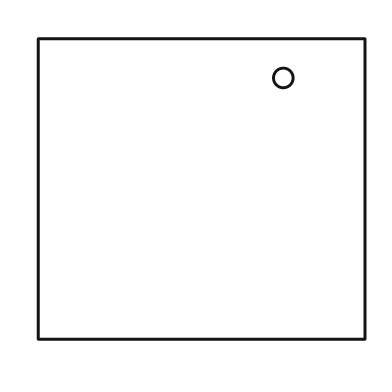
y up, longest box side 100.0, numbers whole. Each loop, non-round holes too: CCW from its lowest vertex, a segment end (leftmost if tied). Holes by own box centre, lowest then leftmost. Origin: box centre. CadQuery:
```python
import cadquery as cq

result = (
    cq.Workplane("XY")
    .moveTo(-50.0, -46.0)
    .lineTo(50.0, -46.0)
    .lineTo(50.0, 46.0)
    .lineTo(-50.0, 46.0)
    .close()
    .moveTo(25.0, 34.0)
    .circle(3.0)
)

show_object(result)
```